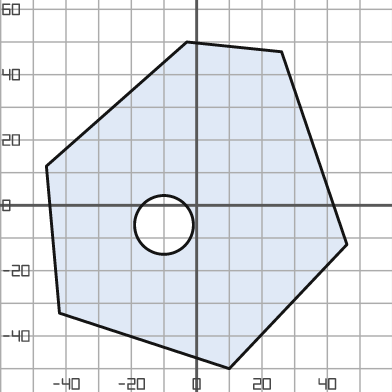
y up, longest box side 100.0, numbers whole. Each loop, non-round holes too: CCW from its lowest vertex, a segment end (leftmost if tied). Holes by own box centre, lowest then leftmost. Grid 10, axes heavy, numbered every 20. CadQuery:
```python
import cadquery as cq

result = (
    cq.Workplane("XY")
    .moveTo(10.0, -50.0)
    .lineTo(46.0, -12.0)
    .lineTo(26.0, 47.0)
    .lineTo(-3.0, 50.0)
    .lineTo(-46.0, 12.0)
    .lineTo(-42.0, -33.0)
    .close()
    .moveTo(-10.0, -6.0)
    .circle(9.0)
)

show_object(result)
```